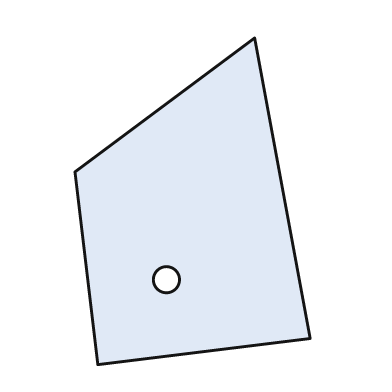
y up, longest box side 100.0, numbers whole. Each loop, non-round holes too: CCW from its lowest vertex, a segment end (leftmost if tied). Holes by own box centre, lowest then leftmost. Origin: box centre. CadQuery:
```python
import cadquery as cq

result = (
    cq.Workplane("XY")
    .moveTo(-29.0, -50.0)
    .lineTo(36.0, -42.0)
    .lineTo(19.0, 50.0)
    .lineTo(-36.0, 9.0)
    .close()
    .moveTo(-8.0, -24.0)
    .circle(4.0)
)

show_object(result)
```